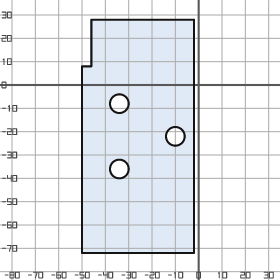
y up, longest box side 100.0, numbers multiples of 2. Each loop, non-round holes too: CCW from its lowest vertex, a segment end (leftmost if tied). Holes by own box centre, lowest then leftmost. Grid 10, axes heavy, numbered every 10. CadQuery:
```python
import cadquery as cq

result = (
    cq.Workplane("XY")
    .moveTo(-50.0, -72.0)
    .lineTo(-2.0, -72.0)
    .lineTo(-2.0, 28.0)
    .lineTo(-46.0, 28.0)
    .lineTo(-46.0, 8.0)
    .lineTo(-50.0, 8.0)
    .close()
    .moveTo(-34.0, -36.0)
    .circle(4.0)
    .moveTo(-10.0, -22.0)
    .circle(4.0)
    .moveTo(-34.0, -8.0)
    .circle(4.0)
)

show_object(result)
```